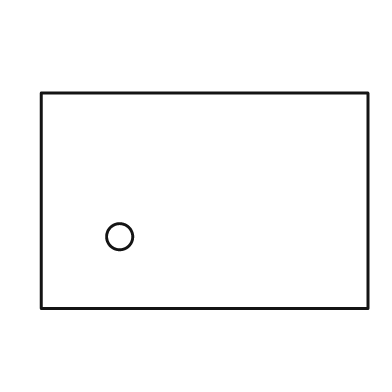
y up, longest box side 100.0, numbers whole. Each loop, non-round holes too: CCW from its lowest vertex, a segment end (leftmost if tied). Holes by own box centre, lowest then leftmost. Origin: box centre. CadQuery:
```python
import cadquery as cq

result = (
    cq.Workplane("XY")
    .moveTo(-50.0, -33.0)
    .lineTo(50.0, -33.0)
    .lineTo(50.0, 33.0)
    .lineTo(-50.0, 33.0)
    .close()
    .moveTo(-26.0, -11.0)
    .circle(4.0)
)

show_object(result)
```